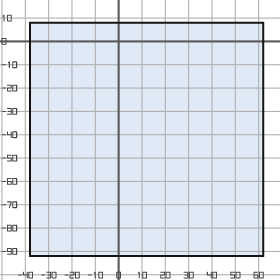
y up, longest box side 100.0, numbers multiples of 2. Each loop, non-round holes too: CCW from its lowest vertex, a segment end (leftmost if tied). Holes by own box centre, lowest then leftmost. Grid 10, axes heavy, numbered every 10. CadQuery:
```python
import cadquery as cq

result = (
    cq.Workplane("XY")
    .moveTo(-38.0, -92.0)
    .lineTo(62.0, -92.0)
    .lineTo(62.0, 8.0)
    .lineTo(-38.0, 8.0)
    .close()
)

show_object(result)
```